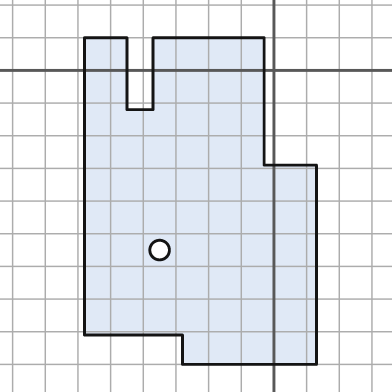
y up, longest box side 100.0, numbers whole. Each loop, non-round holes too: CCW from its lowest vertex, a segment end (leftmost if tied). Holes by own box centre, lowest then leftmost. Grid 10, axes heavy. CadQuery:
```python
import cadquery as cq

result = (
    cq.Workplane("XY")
    .moveTo(-28.0, -90.0)
    .lineTo(13.0, -90.0)
    .lineTo(13.0, -29.0)
    .lineTo(-3.0, -29.0)
    .lineTo(-3.0, 10.0)
    .lineTo(-37.0, 10.0)
    .lineTo(-37.0, -12.0)
    .lineTo(-45.0, -12.0)
    .lineTo(-45.0, 10.0)
    .lineTo(-58.0, 10.0)
    .lineTo(-58.0, -81.0)
    .lineTo(-28.0, -81.0)
    .close()
    .moveTo(-35.0, -55.0)
    .circle(3.0)
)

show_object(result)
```